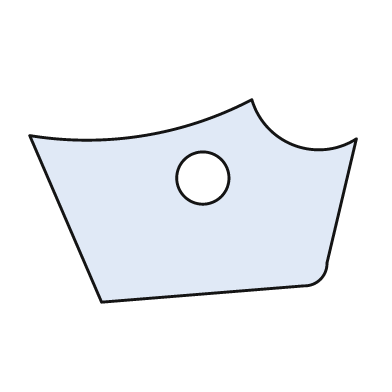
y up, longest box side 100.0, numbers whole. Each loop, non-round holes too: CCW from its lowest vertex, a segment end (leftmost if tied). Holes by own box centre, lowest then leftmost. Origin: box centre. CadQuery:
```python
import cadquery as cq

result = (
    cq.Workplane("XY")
    .moveTo(-28.0, -31.0)
    .lineTo(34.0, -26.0)
    .threePointArc((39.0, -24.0), (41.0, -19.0))
    .lineTo(50.0, 19.0)
    .threePointArc((31.0, 17.0), (18.0, 31.0))
    .threePointArc((-15.0, 20.0), (-50.0, 20.0))
    .close()
    .moveTo(3.0, 7.0)
    .circle(8.0)
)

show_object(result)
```